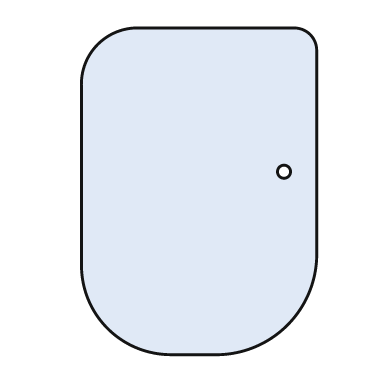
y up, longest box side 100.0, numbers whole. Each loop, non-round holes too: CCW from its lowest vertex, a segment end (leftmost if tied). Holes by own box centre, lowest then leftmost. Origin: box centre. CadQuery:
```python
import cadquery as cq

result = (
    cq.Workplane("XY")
    .moveTo(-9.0, -50.0)
    .lineTo(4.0, -50.0)
    .threePointArc((27.0, -41.0), (36.0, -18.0))
    .lineTo(36.0, 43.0)
    .threePointArc((34.0, 48.0), (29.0, 50.0))
    .lineTo(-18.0, 50.0)
    .threePointArc((-31.0, 45.0), (-36.0, 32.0))
    .lineTo(-36.0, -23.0)
    .threePointArc((-28.0, -42.0), (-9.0, -50.0))
    .close()
    .moveTo(26.0, 6.0)
    .circle(2.0)
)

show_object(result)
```